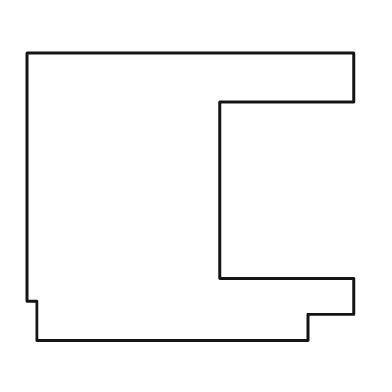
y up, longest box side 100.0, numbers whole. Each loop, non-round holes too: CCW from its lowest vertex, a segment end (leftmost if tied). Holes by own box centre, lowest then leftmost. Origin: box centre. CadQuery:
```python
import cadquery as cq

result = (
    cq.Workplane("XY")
    .moveTo(-47.0, -44.0)
    .lineTo(36.0, -44.0)
    .lineTo(36.0, -36.0)
    .lineTo(50.0, -36.0)
    .lineTo(50.0, -25.0)
    .lineTo(9.0, -25.0)
    .lineTo(9.0, 29.0)
    .lineTo(50.0, 29.0)
    .lineTo(50.0, 44.0)
    .lineTo(-50.0, 44.0)
    .lineTo(-50.0, -32.0)
    .lineTo(-47.0, -32.0)
    .close()
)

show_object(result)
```